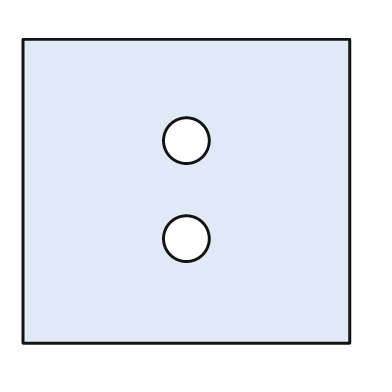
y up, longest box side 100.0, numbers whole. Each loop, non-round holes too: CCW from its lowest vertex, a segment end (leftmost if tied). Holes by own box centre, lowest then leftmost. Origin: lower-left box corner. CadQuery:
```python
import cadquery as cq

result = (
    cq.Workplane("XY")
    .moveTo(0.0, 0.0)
    .lineTo(100.0, 0.0)
    .lineTo(100.0, 93.0)
    .lineTo(0.0, 93.0)
    .close()
    .moveTo(50.0, 32.0)
    .circle(7.0)
    .moveTo(50.0, 62.0)
    .circle(7.0)
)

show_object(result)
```